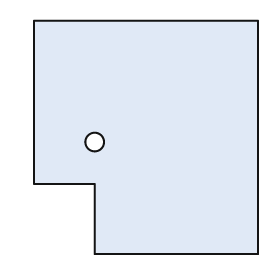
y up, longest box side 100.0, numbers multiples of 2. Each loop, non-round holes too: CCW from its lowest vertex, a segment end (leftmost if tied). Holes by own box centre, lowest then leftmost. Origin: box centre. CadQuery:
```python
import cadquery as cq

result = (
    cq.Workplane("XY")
    .moveTo(-22.0, -50.0)
    .lineTo(48.0, -50.0)
    .lineTo(48.0, 50.0)
    .lineTo(-48.0, 50.0)
    .lineTo(-48.0, -20.0)
    .lineTo(-22.0, -20.0)
    .close()
    .moveTo(-22.0, -2.0)
    .circle(4.0)
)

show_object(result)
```